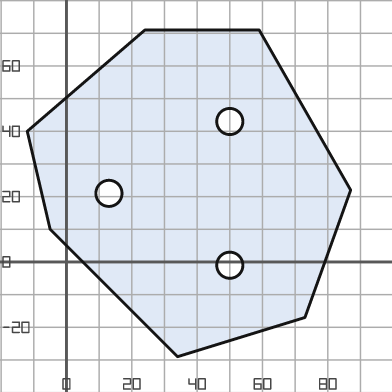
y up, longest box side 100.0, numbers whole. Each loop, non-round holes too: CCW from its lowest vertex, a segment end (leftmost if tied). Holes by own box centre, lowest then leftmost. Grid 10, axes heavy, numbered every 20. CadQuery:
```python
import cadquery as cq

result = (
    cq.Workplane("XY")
    .moveTo(34.0, -29.0)
    .lineTo(73.0, -17.0)
    .lineTo(87.0, 22.0)
    .lineTo(59.0, 71.0)
    .lineTo(24.0, 71.0)
    .lineTo(-12.0, 40.0)
    .lineTo(-5.0, 10.0)
    .close()
    .moveTo(50.0, -1.0)
    .circle(4.0)
    .moveTo(13.0, 21.0)
    .circle(4.0)
    .moveTo(50.0, 43.0)
    .circle(4.0)
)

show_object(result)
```